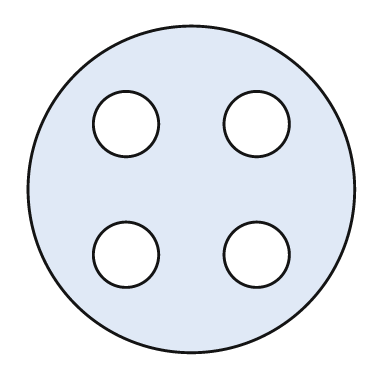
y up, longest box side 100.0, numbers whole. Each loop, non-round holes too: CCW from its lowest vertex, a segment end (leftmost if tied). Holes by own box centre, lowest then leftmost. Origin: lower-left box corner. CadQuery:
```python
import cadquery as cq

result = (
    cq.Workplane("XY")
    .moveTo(50.0, 50.0)
    .circle(50.0)
    .moveTo(30.0, 30.0)
    .circle(10.0)
    .moveTo(70.0, 30.0)
    .circle(10.0)
    .moveTo(30.0, 70.0)
    .circle(10.0)
    .moveTo(70.0, 70.0)
    .circle(10.0)
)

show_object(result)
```